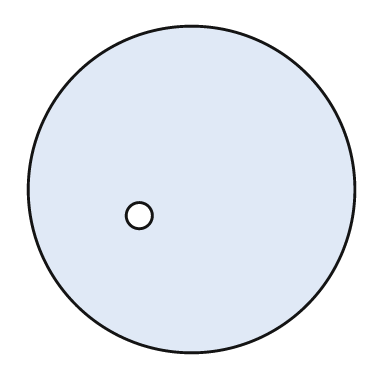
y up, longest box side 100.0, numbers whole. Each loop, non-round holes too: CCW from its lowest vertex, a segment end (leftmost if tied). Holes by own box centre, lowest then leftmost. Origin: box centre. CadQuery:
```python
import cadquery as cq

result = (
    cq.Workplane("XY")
    .moveTo(0.0, 0.0)
    .circle(50.0)
    .moveTo(-16.0, -8.0)
    .circle(4.0)
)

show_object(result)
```